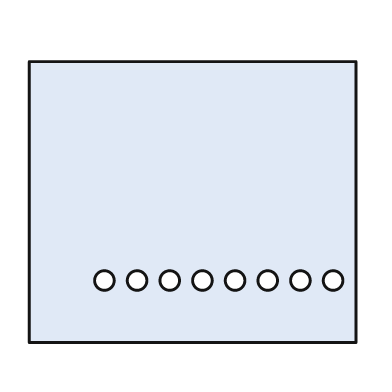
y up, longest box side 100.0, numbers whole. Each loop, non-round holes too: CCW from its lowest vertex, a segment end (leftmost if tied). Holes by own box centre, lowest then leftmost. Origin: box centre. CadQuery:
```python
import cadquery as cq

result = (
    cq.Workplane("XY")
    .moveTo(-50.0, -43.0)
    .lineTo(50.0, -43.0)
    .lineTo(50.0, 43.0)
    .lineTo(-50.0, 43.0)
    .close()
    .moveTo(-27.0, -24.0)
    .circle(3.0)
    .moveTo(-17.0, -24.0)
    .circle(3.0)
    .moveTo(-7.0, -24.0)
    .circle(3.0)
    .moveTo(3.0, -24.0)
    .circle(3.0)
    .moveTo(13.0, -24.0)
    .circle(3.0)
    .moveTo(23.0, -24.0)
    .circle(3.0)
    .moveTo(33.0, -24.0)
    .circle(3.0)
    .moveTo(43.0, -24.0)
    .circle(3.0)
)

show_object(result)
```